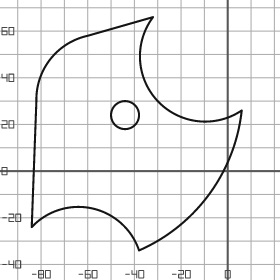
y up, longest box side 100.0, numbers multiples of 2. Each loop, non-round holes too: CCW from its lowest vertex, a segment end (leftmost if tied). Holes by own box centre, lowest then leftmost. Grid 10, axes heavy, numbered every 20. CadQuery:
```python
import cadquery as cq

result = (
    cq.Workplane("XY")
    .moveTo(-38.0, -34.0)
    .threePointArc((-8.0, -10.0), (6.0, 26.0))
    .threePointArc((-30.0, 30.0), (-32.0, 66.0))
    .lineTo(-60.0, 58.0)
    .threePointArc((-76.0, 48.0), (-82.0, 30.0))
    .lineTo(-84.0, -24.0)
    .threePointArc((-58.0, -16.0), (-38.0, -34.0))
    .close()
    .moveTo(-44.0, 24.0)
    .circle(6.0)
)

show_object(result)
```